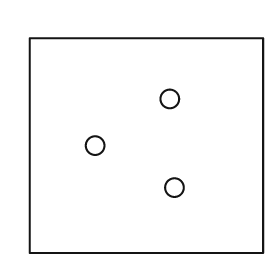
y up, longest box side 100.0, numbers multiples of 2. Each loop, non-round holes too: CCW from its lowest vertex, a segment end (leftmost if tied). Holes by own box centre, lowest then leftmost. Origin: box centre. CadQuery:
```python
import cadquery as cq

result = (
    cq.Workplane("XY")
    .moveTo(-50.0, -46.0)
    .lineTo(50.0, -46.0)
    .lineTo(50.0, 46.0)
    .lineTo(-50.0, 46.0)
    .close()
    .moveTo(12.0, -18.0)
    .circle(4.0)
    .moveTo(-22.0, 0.0)
    .circle(4.0)
    .moveTo(10.0, 20.0)
    .circle(4.0)
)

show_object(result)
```